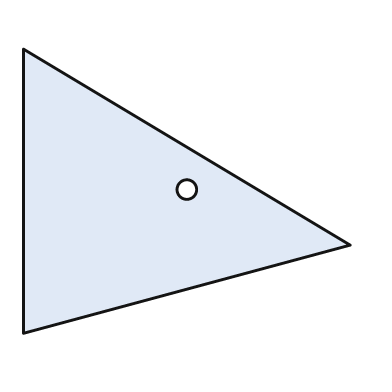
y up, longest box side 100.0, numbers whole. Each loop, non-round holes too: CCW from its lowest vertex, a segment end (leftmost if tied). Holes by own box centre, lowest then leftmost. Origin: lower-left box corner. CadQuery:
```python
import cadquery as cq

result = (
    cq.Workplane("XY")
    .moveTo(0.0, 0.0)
    .lineTo(100.0, 27.0)
    .lineTo(0.0, 87.0)
    .close()
    .moveTo(50.0, 44.0)
    .circle(3.0)
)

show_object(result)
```